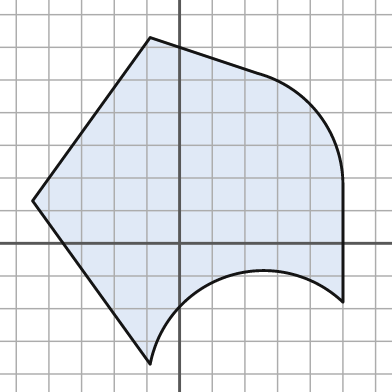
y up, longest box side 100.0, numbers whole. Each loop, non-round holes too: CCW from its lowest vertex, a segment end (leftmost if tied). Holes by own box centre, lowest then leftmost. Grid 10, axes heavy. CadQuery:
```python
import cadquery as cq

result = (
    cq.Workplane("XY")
    .moveTo(-9.0, -37.0)
    .threePointArc((15.0, -10.0), (50.0, -18.0))
    .lineTo(50.0, 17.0)
    .threePointArc((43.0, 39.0), (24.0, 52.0))
    .lineTo(-9.0, 63.0)
    .lineTo(-45.0, 13.0)
    .close()
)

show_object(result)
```